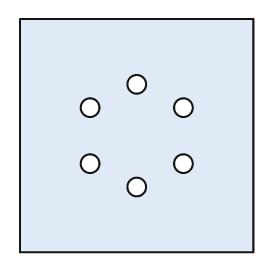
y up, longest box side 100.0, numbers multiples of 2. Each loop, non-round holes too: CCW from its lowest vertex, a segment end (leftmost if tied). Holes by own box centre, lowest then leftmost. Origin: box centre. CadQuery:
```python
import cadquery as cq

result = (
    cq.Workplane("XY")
    .moveTo(-50.0, -50.0)
    .lineTo(50.0, -50.0)
    .lineTo(50.0, 50.0)
    .lineTo(-50.0, 50.0)
    .close()
    .moveTo(0.0, -22.0)
    .circle(4.0)
    .moveTo(-20.0, -12.0)
    .circle(4.0)
    .moveTo(20.0, -12.0)
    .circle(4.0)
    .moveTo(-20.0, 12.0)
    .circle(4.0)
    .moveTo(20.0, 12.0)
    .circle(4.0)
    .moveTo(0.0, 22.0)
    .circle(4.0)
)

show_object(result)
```